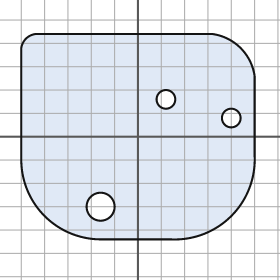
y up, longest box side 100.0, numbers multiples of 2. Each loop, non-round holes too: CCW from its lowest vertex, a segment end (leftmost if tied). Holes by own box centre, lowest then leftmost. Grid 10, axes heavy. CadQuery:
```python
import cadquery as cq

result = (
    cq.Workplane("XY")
    .moveTo(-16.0, -44.0)
    .lineTo(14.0, -44.0)
    .threePointArc((40.0, -34.0), (50.0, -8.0))
    .lineTo(50.0, 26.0)
    .threePointArc((44.0, 38.0), (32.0, 44.0))
    .lineTo(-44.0, 44.0)
    .threePointArc((-48.0, 42.0), (-50.0, 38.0))
    .lineTo(-50.0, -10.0)
    .threePointArc((-40.0, -34.0), (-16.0, -44.0))
    .close()
    .moveTo(-16.0, -30.0)
    .circle(6.0)
    .moveTo(40.0, 8.0)
    .circle(4.0)
    .moveTo(12.0, 16.0)
    .circle(4.0)
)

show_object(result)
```